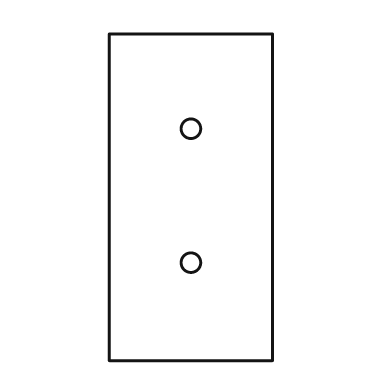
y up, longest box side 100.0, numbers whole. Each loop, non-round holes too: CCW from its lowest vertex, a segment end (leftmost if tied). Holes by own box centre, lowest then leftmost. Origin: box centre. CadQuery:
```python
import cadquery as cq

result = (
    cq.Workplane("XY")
    .moveTo(-25.0, -50.0)
    .lineTo(25.0, -50.0)
    .lineTo(25.0, 50.0)
    .lineTo(-25.0, 50.0)
    .close()
    .moveTo(0.0, -20.0)
    .circle(3.0)
    .moveTo(0.0, 21.0)
    .circle(3.0)
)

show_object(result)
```